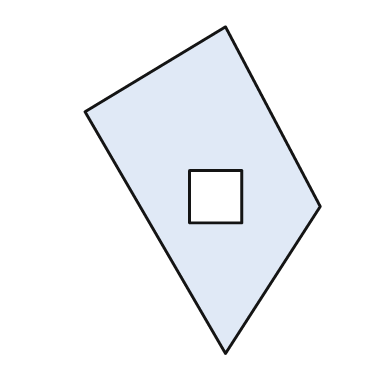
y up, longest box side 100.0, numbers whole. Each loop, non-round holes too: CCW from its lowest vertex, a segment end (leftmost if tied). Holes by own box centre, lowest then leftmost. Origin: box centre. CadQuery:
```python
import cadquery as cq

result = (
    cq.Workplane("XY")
    .moveTo(7.0, -50.0)
    .lineTo(36.0, -5.0)
    .lineTo(7.0, 50.0)
    .lineTo(-36.0, 24.0)
    .close()
    .moveTo(-4.0, -10.0)
    .lineTo(12.0, -10.0)
    .lineTo(12.0, 6.0)
    .lineTo(-4.0, 6.0)
    .close()
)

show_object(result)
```